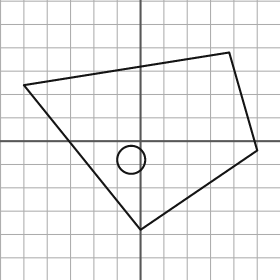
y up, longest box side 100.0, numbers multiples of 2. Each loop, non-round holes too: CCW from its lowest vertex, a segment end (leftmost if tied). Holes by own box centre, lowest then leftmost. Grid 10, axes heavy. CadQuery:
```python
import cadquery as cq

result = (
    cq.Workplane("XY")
    .moveTo(0.0, -38.0)
    .lineTo(50.0, -4.0)
    .lineTo(38.0, 38.0)
    .lineTo(-50.0, 24.0)
    .close()
    .moveTo(-4.0, -8.0)
    .circle(6.0)
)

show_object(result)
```